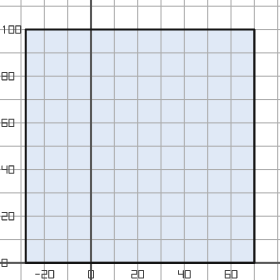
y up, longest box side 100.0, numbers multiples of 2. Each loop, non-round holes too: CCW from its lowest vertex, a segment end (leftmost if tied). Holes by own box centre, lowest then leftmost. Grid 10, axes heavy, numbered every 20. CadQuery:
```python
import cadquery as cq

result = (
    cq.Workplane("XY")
    .moveTo(-28.0, 0.0)
    .lineTo(70.0, 0.0)
    .lineTo(70.0, 100.0)
    .lineTo(-28.0, 100.0)
    .close()
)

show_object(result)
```